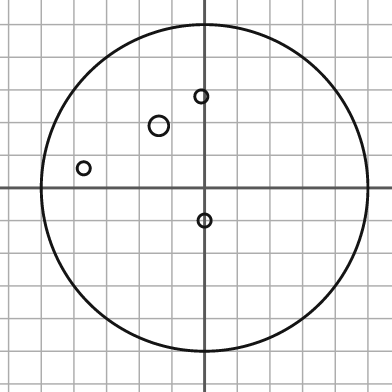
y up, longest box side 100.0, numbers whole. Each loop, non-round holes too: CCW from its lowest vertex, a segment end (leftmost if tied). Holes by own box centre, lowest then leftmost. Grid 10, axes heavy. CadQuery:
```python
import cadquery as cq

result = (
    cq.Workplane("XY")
    .moveTo(0.0, 0.0)
    .circle(50.0)
    .moveTo(0.0, -10.0)
    .circle(2.0)
    .moveTo(-37.0, 6.0)
    .circle(2.0)
    .moveTo(-14.0, 19.0)
    .circle(3.0)
    .moveTo(-1.0, 28.0)
    .circle(2.0)
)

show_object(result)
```